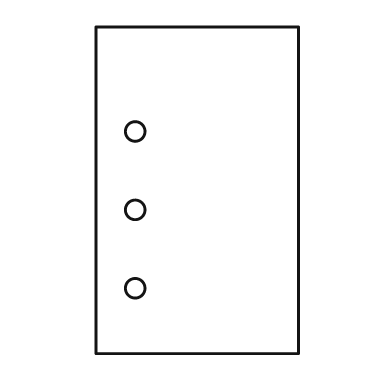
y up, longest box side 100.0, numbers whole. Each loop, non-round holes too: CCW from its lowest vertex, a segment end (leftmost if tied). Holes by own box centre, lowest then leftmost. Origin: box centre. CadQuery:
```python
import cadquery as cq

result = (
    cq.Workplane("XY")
    .moveTo(-31.0, -50.0)
    .lineTo(31.0, -50.0)
    .lineTo(31.0, 50.0)
    .lineTo(-31.0, 50.0)
    .close()
    .moveTo(-19.0, -30.0)
    .circle(3.0)
    .moveTo(-19.0, -6.0)
    .circle(3.0)
    .moveTo(-19.0, 18.0)
    .circle(3.0)
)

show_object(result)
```